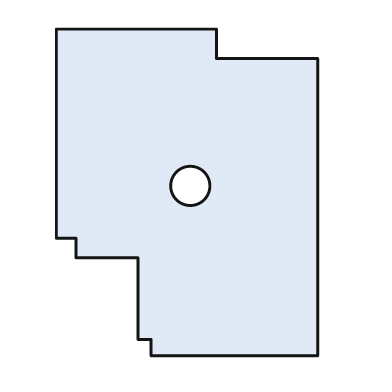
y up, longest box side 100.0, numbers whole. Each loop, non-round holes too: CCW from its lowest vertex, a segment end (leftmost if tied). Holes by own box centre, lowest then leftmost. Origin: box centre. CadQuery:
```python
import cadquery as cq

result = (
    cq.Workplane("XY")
    .moveTo(-11.0, -50.0)
    .lineTo(40.0, -50.0)
    .lineTo(40.0, 41.0)
    .lineTo(9.0, 41.0)
    .lineTo(9.0, 50.0)
    .lineTo(-40.0, 50.0)
    .lineTo(-40.0, -14.0)
    .lineTo(-34.0, -14.0)
    .lineTo(-34.0, -20.0)
    .lineTo(-15.0, -20.0)
    .lineTo(-15.0, -45.0)
    .lineTo(-11.0, -45.0)
    .close()
    .moveTo(1.0, 2.0)
    .circle(6.0)
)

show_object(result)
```